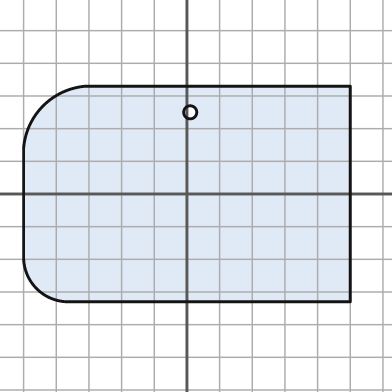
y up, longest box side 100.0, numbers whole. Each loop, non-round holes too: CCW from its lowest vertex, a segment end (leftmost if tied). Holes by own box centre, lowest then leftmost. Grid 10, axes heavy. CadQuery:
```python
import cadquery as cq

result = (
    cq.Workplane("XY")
    .moveTo(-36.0, -33.0)
    .lineTo(50.0, -33.0)
    .lineTo(50.0, 33.0)
    .lineTo(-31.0, 33.0)
    .threePointArc((-44.0, 27.0), (-50.0, 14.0))
    .lineTo(-50.0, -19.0)
    .threePointArc((-46.0, -29.0), (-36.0, -33.0))
    .close()
    .moveTo(1.0, 25.0)
    .circle(2.0)
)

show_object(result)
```